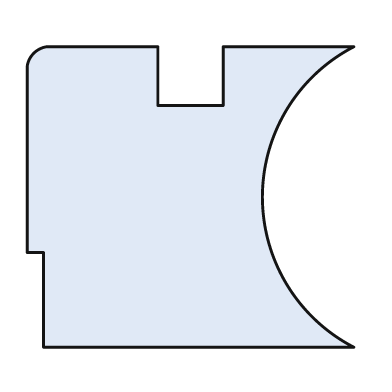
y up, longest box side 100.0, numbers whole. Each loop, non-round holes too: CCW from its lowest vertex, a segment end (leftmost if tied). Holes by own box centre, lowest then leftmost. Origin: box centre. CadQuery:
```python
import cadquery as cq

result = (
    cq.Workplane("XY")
    .moveTo(-45.0, -46.0)
    .lineTo(50.0, -46.0)
    .threePointArc((22.0, 0.0), (50.0, 46.0))
    .lineTo(10.0, 46.0)
    .lineTo(10.0, 28.0)
    .lineTo(-10.0, 28.0)
    .lineTo(-10.0, 46.0)
    .lineTo(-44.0, 46.0)
    .threePointArc((-48.0, 44.0), (-50.0, 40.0))
    .lineTo(-50.0, -17.0)
    .lineTo(-45.0, -17.0)
    .close()
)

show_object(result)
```